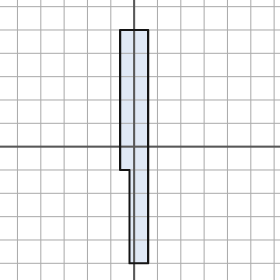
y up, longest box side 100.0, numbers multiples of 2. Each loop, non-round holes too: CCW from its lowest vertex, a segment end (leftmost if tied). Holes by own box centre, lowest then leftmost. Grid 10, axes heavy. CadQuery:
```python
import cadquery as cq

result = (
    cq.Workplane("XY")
    .moveTo(-2.0, -50.0)
    .lineTo(6.0, -50.0)
    .lineTo(6.0, 50.0)
    .lineTo(-6.0, 50.0)
    .lineTo(-6.0, -10.0)
    .lineTo(-2.0, -10.0)
    .close()
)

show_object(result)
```